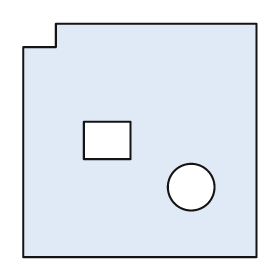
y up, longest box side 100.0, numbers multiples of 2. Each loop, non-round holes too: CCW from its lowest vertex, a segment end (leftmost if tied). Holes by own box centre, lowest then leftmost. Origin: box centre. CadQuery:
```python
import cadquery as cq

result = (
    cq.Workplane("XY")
    .moveTo(-50.0, -50.0)
    .lineTo(50.0, -50.0)
    .lineTo(50.0, 50.0)
    .lineTo(-36.0, 50.0)
    .lineTo(-36.0, 40.0)
    .lineTo(-50.0, 40.0)
    .close()
    .moveTo(22.0, -20.0)
    .circle(10.0)
    .moveTo(-24.0, -8.0)
    .lineTo(-4.0, -8.0)
    .lineTo(-4.0, 8.0)
    .lineTo(-24.0, 8.0)
    .close()
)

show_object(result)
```